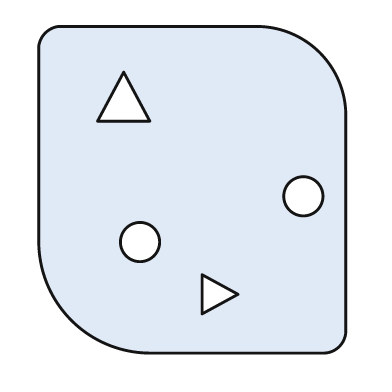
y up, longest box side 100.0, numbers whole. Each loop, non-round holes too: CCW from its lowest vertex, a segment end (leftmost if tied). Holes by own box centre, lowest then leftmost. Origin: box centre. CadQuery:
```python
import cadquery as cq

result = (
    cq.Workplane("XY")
    .moveTo(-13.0, -50.0)
    .lineTo(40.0, -50.0)
    .threePointArc((45.0, -48.0), (47.0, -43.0))
    .lineTo(47.0, 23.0)
    .threePointArc((39.0, 42.0), (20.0, 50.0))
    .lineTo(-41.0, 50.0)
    .threePointArc((-45.0, 48.0), (-47.0, 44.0))
    .lineTo(-47.0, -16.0)
    .threePointArc((-37.0, -40.0), (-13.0, -50.0))
    .close()
    .moveTo(3.0, -38.0)
    .lineTo(14.0, -32.0)
    .lineTo(3.0, -26.0)
    .close()
    .moveTo(-16.0, -16.0)
    .circle(6.0)
    .moveTo(34.0, -2.0)
    .circle(6.0)
    .moveTo(-29.0, 21.0)
    .lineTo(-13.0, 21.0)
    .lineTo(-21.0, 36.0)
    .close()
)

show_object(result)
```